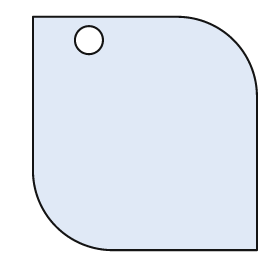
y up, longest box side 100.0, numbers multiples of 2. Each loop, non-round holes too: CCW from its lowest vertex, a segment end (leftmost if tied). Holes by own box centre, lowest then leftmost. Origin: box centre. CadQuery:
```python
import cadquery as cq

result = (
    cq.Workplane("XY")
    .moveTo(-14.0, -50.0)
    .lineTo(48.0, -50.0)
    .lineTo(48.0, 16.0)
    .threePointArc((38.0, 40.0), (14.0, 50.0))
    .lineTo(-48.0, 50.0)
    .lineTo(-48.0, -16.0)
    .threePointArc((-38.0, -40.0), (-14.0, -50.0))
    .close()
    .moveTo(-24.0, 40.0)
    .circle(6.0)
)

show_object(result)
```